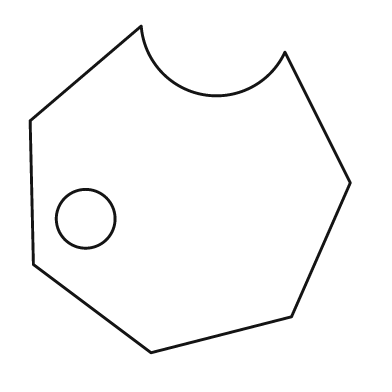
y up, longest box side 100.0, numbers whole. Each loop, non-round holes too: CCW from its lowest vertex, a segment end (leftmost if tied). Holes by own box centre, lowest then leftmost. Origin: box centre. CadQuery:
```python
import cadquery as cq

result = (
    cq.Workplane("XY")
    .moveTo(-12.0, -50.0)
    .lineTo(31.0, -39.0)
    .lineTo(49.0, 2.0)
    .lineTo(29.0, 42.0)
    .threePointArc((4.0, 29.0), (-15.0, 50.0))
    .lineTo(-49.0, 21.0)
    .lineTo(-48.0, -23.0)
    .close()
    .moveTo(-32.0, -9.0)
    .circle(9.0)
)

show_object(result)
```